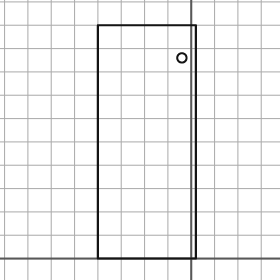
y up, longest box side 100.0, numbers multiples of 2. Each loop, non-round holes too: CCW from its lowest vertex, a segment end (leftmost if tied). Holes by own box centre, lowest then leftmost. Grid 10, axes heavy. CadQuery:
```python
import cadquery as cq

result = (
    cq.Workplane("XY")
    .moveTo(-40.0, 0.0)
    .lineTo(2.0, 0.0)
    .lineTo(2.0, 100.0)
    .lineTo(-40.0, 100.0)
    .close()
    .moveTo(-4.0, 86.0)
    .circle(2.0)
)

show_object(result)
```